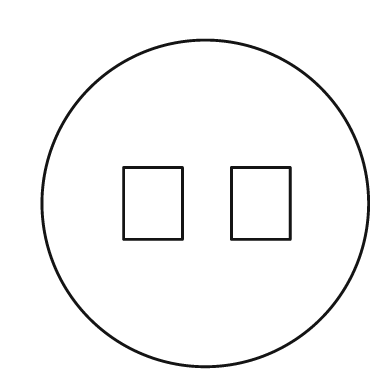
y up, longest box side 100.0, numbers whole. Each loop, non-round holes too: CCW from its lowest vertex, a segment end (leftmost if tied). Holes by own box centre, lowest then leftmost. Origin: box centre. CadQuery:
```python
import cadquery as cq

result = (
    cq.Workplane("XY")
    .moveTo(0.0, 0.0)
    .circle(50.0)
    .moveTo(-25.0, -11.0)
    .lineTo(-7.0, -11.0)
    .lineTo(-7.0, 11.0)
    .lineTo(-25.0, 11.0)
    .close()
    .moveTo(8.0, -11.0)
    .lineTo(26.0, -11.0)
    .lineTo(26.0, 11.0)
    .lineTo(8.0, 11.0)
    .close()
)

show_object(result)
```